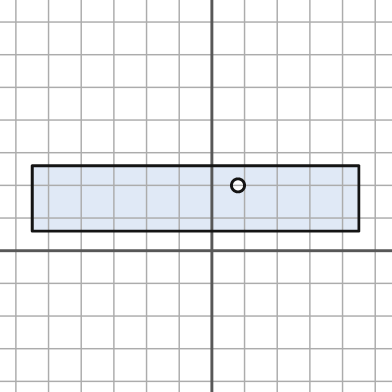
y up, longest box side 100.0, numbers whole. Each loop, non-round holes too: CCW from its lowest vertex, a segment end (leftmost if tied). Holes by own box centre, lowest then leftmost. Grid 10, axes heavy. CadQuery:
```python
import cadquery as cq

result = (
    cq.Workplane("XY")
    .moveTo(-55.0, 6.0)
    .lineTo(45.0, 6.0)
    .lineTo(45.0, 26.0)
    .lineTo(-55.0, 26.0)
    .close()
    .moveTo(8.0, 20.0)
    .circle(2.0)
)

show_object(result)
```